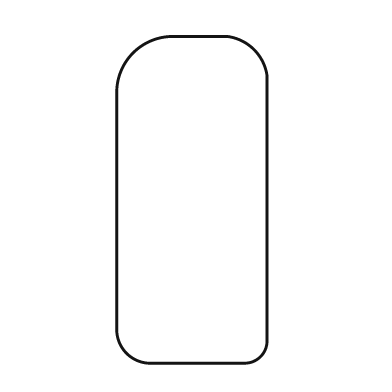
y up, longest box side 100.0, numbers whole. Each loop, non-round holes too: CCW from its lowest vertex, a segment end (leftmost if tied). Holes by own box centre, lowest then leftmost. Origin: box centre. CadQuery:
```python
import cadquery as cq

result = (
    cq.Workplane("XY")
    .moveTo(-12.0, -50.0)
    .lineTo(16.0, -50.0)
    .threePointArc((21.0, -48.0), (23.0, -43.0))
    .lineTo(23.0, 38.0)
    .threePointArc((19.0, 46.0), (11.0, 50.0))
    .lineTo(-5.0, 50.0)
    .threePointArc((-18.0, 45.0), (-23.0, 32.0))
    .lineTo(-23.0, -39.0)
    .threePointArc((-20.0, -47.0), (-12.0, -50.0))
    .close()
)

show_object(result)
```